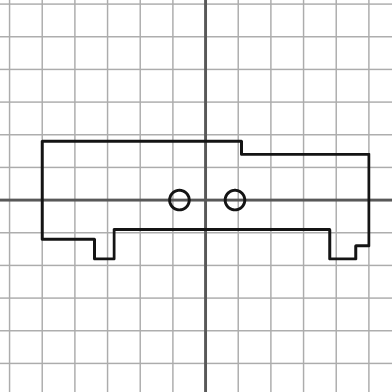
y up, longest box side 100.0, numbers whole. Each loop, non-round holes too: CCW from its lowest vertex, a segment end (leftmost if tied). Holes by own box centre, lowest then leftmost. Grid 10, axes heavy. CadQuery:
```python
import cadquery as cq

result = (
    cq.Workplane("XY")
    .moveTo(-34.0, -18.0)
    .lineTo(-28.0, -18.0)
    .lineTo(-28.0, -9.0)
    .lineTo(38.0, -9.0)
    .lineTo(38.0, -18.0)
    .lineTo(46.0, -18.0)
    .lineTo(46.0, -14.0)
    .lineTo(50.0, -14.0)
    .lineTo(50.0, 14.0)
    .lineTo(11.0, 14.0)
    .lineTo(11.0, 18.0)
    .lineTo(-50.0, 18.0)
    .lineTo(-50.0, -12.0)
    .lineTo(-34.0, -12.0)
    .close()
    .moveTo(-8.0, 0.0)
    .circle(3.0)
    .moveTo(9.0, 0.0)
    .circle(3.0)
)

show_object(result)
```